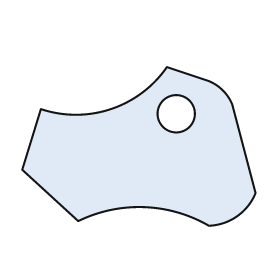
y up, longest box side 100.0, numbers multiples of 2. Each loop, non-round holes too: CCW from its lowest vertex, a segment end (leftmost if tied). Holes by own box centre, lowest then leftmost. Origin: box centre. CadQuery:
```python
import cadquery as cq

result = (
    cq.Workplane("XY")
    .moveTo(30.0, -34.0)
    .threePointArc((42.0, -30.0), (50.0, -20.0))
    .lineTo(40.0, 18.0)
    .threePointArc((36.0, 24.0), (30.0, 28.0))
    .lineTo(12.0, 34.0)
    .threePointArc((-12.0, 16.0), (-42.0, 16.0))
    .lineTo(-50.0, -10.0)
    .lineTo(-26.0, -32.0)
    .threePointArc((2.0, -26.0), (30.0, -34.0))
    .close()
    .moveTo(16.0, 14.0)
    .circle(8.0)
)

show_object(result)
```